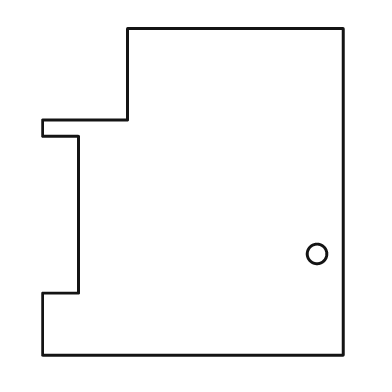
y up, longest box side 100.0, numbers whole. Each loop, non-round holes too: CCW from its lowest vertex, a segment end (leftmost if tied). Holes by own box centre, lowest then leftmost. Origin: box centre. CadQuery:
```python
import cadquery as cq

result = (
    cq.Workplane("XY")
    .moveTo(-46.0, -50.0)
    .lineTo(46.0, -50.0)
    .lineTo(46.0, 50.0)
    .lineTo(-20.0, 50.0)
    .lineTo(-20.0, 22.0)
    .lineTo(-46.0, 22.0)
    .lineTo(-46.0, 17.0)
    .lineTo(-35.0, 17.0)
    .lineTo(-35.0, -31.0)
    .lineTo(-46.0, -31.0)
    .close()
    .moveTo(38.0, -19.0)
    .circle(3.0)
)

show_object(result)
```